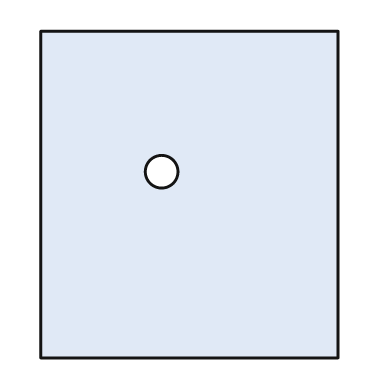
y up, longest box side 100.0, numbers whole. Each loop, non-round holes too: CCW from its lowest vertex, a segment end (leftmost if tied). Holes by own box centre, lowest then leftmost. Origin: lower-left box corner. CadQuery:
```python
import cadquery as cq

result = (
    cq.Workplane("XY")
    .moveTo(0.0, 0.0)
    .lineTo(91.0, 0.0)
    .lineTo(91.0, 100.0)
    .lineTo(0.0, 100.0)
    .close()
    .moveTo(37.0, 57.0)
    .circle(5.0)
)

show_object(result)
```